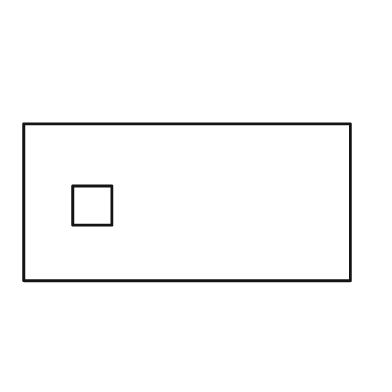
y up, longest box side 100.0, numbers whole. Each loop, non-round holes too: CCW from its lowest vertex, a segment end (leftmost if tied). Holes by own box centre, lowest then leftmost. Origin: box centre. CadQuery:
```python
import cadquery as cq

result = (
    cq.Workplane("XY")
    .moveTo(-50.0, -24.0)
    .lineTo(50.0, -24.0)
    .lineTo(50.0, 24.0)
    .lineTo(-50.0, 24.0)
    .close()
    .moveTo(-35.0, -7.0)
    .lineTo(-23.0, -7.0)
    .lineTo(-23.0, 5.0)
    .lineTo(-35.0, 5.0)
    .close()
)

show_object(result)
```